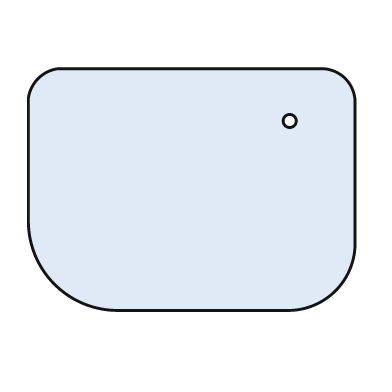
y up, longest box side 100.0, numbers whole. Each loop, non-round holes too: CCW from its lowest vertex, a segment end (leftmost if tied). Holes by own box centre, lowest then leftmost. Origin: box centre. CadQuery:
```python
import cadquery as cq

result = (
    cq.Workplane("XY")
    .moveTo(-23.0, -37.0)
    .lineTo(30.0, -37.0)
    .threePointArc((44.0, -31.0), (50.0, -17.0))
    .lineTo(50.0, 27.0)
    .threePointArc((47.0, 34.0), (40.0, 37.0))
    .lineTo(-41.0, 37.0)
    .threePointArc((-47.0, 34.0), (-50.0, 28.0))
    .lineTo(-50.0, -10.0)
    .threePointArc((-42.0, -29.0), (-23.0, -37.0))
    .close()
    .moveTo(30.0, 21.0)
    .circle(2.0)
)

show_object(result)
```